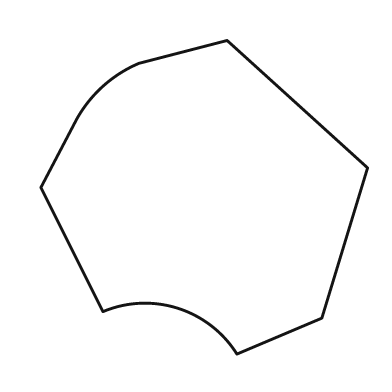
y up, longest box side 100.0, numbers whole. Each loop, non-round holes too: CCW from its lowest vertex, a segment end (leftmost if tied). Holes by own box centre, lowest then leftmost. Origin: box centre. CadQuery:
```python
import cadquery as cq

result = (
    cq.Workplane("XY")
    .moveTo(10.0, -48.0)
    .lineTo(36.0, -37.0)
    .lineTo(50.0, 9.0)
    .lineTo(7.0, 48.0)
    .lineTo(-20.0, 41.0)
    .threePointArc((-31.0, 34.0), (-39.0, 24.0))
    .lineTo(-50.0, 3.0)
    .lineTo(-31.0, -35.0)
    .threePointArc((-8.0, -34.0), (10.0, -48.0))
    .close()
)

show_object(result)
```